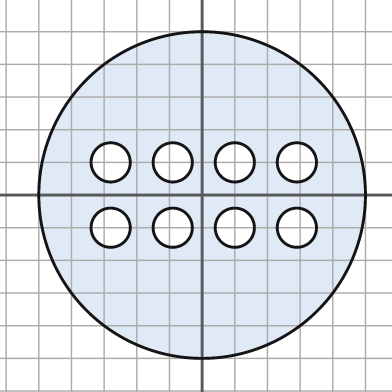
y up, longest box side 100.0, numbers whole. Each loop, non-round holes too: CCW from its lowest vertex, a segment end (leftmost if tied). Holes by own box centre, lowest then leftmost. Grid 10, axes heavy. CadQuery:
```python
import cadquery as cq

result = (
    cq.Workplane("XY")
    .moveTo(0.0, 0.0)
    .circle(50.0)
    .moveTo(-28.0, -10.0)
    .circle(6.0)
    .moveTo(-9.0, -10.0)
    .circle(6.0)
    .moveTo(10.0, -10.0)
    .circle(6.0)
    .moveTo(29.0, -10.0)
    .circle(6.0)
    .moveTo(-28.0, 10.0)
    .circle(6.0)
    .moveTo(-9.0, 10.0)
    .circle(6.0)
    .moveTo(10.0, 10.0)
    .circle(6.0)
    .moveTo(29.0, 10.0)
    .circle(6.0)
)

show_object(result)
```